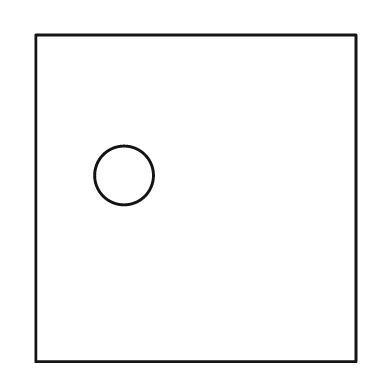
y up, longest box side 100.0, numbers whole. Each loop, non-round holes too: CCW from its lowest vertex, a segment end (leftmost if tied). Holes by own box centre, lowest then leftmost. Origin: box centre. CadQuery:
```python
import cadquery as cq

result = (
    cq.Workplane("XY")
    .moveTo(-49.0, -50.0)
    .lineTo(49.0, -50.0)
    .lineTo(49.0, 50.0)
    .lineTo(-49.0, 50.0)
    .close()
    .moveTo(-22.0, 7.0)
    .circle(9.0)
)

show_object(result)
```